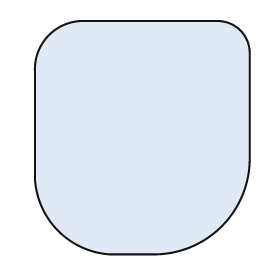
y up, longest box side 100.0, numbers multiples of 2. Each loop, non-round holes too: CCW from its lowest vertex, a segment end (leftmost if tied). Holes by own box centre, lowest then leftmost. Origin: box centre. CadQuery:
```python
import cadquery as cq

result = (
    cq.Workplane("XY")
    .moveTo(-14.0, -50.0)
    .lineTo(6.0, -50.0)
    .threePointArc((34.0, -38.0), (46.0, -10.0))
    .lineTo(46.0, 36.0)
    .threePointArc((42.0, 46.0), (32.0, 50.0))
    .lineTo(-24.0, 50.0)
    .threePointArc((-40.0, 44.0), (-46.0, 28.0))
    .lineTo(-46.0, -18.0)
    .threePointArc((-36.0, -40.0), (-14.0, -50.0))
    .close()
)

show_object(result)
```